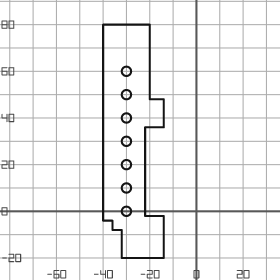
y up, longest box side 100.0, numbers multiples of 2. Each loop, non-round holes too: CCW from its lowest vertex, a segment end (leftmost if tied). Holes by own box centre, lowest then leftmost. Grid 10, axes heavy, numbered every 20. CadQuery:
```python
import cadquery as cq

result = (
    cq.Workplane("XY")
    .moveTo(-32.0, -20.0)
    .lineTo(-14.0, -20.0)
    .lineTo(-14.0, -2.0)
    .lineTo(-22.0, -2.0)
    .lineTo(-22.0, 36.0)
    .lineTo(-14.0, 36.0)
    .lineTo(-14.0, 48.0)
    .lineTo(-20.0, 48.0)
    .lineTo(-20.0, 80.0)
    .lineTo(-40.0, 80.0)
    .lineTo(-40.0, -4.0)
    .lineTo(-36.0, -4.0)
    .lineTo(-36.0, -8.0)
    .lineTo(-32.0, -8.0)
    .close()
    .moveTo(-30.0, 0.0)
    .circle(2.0)
    .moveTo(-30.0, 10.0)
    .circle(2.0)
    .moveTo(-30.0, 20.0)
    .circle(2.0)
    .moveTo(-30.0, 30.0)
    .circle(2.0)
    .moveTo(-30.0, 40.0)
    .circle(2.0)
    .moveTo(-30.0, 50.0)
    .circle(2.0)
    .moveTo(-30.0, 60.0)
    .circle(2.0)
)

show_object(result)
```